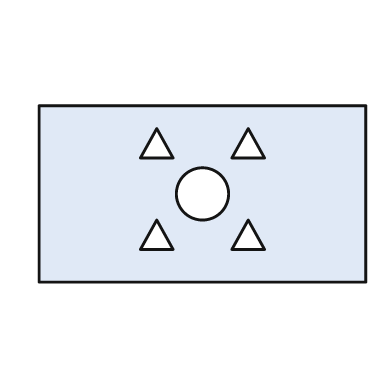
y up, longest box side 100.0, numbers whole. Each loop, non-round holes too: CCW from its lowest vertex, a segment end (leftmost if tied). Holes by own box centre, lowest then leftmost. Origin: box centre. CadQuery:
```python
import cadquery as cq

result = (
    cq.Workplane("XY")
    .moveTo(-50.0, -27.0)
    .lineTo(50.0, -27.0)
    .lineTo(50.0, 27.0)
    .lineTo(-50.0, 27.0)
    .close()
    .moveTo(-19.0, -17.0)
    .lineTo(-9.0, -17.0)
    .lineTo(-14.0, -8.0)
    .close()
    .moveTo(9.0, -17.0)
    .lineTo(19.0, -17.0)
    .lineTo(14.0, -8.0)
    .close()
    .moveTo(0.0, 0.0)
    .circle(8.0)
    .moveTo(-19.0, 11.0)
    .lineTo(-9.0, 11.0)
    .lineTo(-14.0, 20.0)
    .close()
    .moveTo(9.0, 11.0)
    .lineTo(19.0, 11.0)
    .lineTo(14.0, 20.0)
    .close()
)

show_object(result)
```